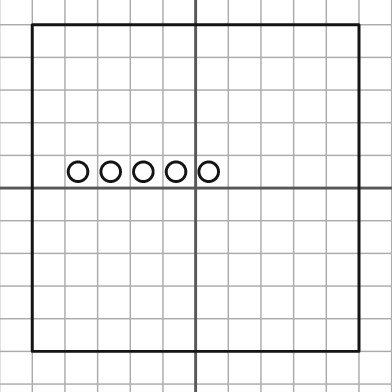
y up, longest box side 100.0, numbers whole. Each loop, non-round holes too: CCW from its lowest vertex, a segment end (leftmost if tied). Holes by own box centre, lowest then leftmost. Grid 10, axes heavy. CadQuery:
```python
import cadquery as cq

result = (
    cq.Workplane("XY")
    .moveTo(-50.0, -50.0)
    .lineTo(50.0, -50.0)
    .lineTo(50.0, 50.0)
    .lineTo(-50.0, 50.0)
    .close()
    .moveTo(-36.0, 5.0)
    .circle(3.0)
    .moveTo(-26.0, 5.0)
    .circle(3.0)
    .moveTo(-16.0, 5.0)
    .circle(3.0)
    .moveTo(-6.0, 5.0)
    .circle(3.0)
    .moveTo(4.0, 5.0)
    .circle(3.0)
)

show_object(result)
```